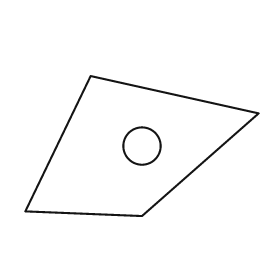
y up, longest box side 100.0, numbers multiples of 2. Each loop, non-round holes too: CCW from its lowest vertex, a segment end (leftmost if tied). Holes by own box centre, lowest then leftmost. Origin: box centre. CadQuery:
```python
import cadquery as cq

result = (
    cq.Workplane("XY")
    .moveTo(0.0, -30.0)
    .lineTo(50.0, 14.0)
    .lineTo(-22.0, 30.0)
    .lineTo(-50.0, -28.0)
    .close()
    .moveTo(0.0, 0.0)
    .circle(8.0)
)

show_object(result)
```